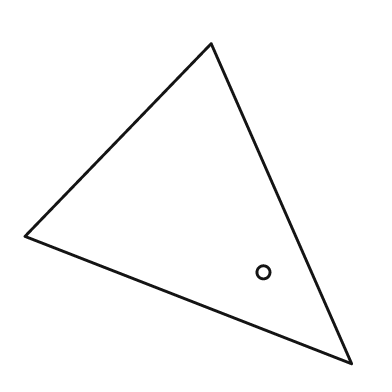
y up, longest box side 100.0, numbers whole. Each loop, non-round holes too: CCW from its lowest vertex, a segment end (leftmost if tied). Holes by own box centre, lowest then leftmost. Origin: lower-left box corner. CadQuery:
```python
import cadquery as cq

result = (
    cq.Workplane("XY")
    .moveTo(100.0, 0.0)
    .lineTo(57.0, 98.0)
    .lineTo(0.0, 39.0)
    .close()
    .moveTo(73.0, 28.0)
    .circle(2.0)
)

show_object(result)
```